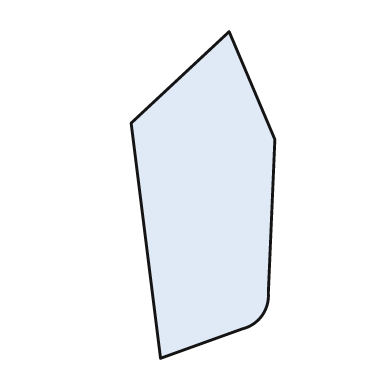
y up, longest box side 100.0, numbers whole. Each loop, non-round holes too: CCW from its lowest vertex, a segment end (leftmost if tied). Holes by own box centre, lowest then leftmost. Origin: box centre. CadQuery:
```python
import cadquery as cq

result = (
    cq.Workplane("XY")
    .moveTo(-13.0, -50.0)
    .lineTo(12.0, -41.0)
    .threePointArc((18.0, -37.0), (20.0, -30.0))
    .lineTo(22.0, 17.0)
    .lineTo(8.0, 50.0)
    .lineTo(-22.0, 22.0)
    .close()
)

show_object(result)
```